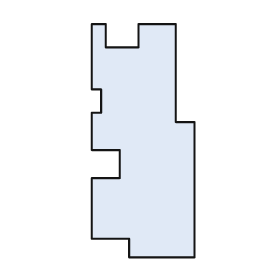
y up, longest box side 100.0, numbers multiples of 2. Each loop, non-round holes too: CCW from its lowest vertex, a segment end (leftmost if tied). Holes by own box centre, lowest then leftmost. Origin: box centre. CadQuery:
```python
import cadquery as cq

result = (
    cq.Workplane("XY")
    .moveTo(-6.0, -50.0)
    .lineTo(22.0, -50.0)
    .lineTo(22.0, 8.0)
    .lineTo(14.0, 8.0)
    .lineTo(14.0, 50.0)
    .lineTo(-2.0, 50.0)
    .lineTo(-2.0, 40.0)
    .lineTo(-16.0, 40.0)
    .lineTo(-16.0, 50.0)
    .lineTo(-22.0, 50.0)
    .lineTo(-22.0, 22.0)
    .lineTo(-18.0, 22.0)
    .lineTo(-18.0, 12.0)
    .lineTo(-22.0, 12.0)
    .lineTo(-22.0, -4.0)
    .lineTo(-10.0, -4.0)
    .lineTo(-10.0, -16.0)
    .lineTo(-22.0, -16.0)
    .lineTo(-22.0, -42.0)
    .lineTo(-6.0, -42.0)
    .close()
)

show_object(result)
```